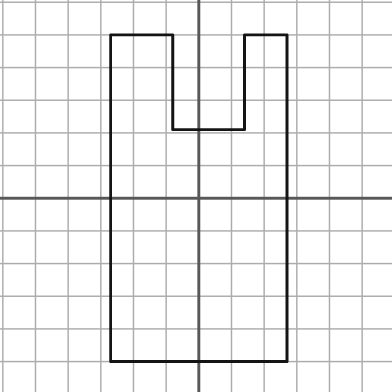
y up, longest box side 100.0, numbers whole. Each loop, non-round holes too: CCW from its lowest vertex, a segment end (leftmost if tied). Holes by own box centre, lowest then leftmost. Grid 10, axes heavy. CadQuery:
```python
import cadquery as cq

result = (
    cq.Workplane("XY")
    .moveTo(-27.0, -50.0)
    .lineTo(27.0, -50.0)
    .lineTo(27.0, 50.0)
    .lineTo(14.0, 50.0)
    .lineTo(14.0, 21.0)
    .lineTo(-8.0, 21.0)
    .lineTo(-8.0, 50.0)
    .lineTo(-27.0, 50.0)
    .close()
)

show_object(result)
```